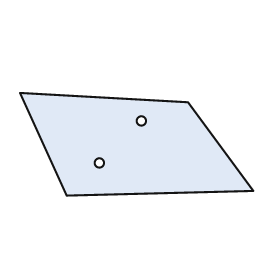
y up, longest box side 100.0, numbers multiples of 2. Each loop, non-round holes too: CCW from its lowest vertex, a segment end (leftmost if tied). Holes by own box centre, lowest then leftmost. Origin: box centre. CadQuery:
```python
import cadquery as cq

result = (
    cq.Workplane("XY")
    .moveTo(-30.0, -22.0)
    .lineTo(50.0, -20.0)
    .lineTo(22.0, 18.0)
    .lineTo(-50.0, 22.0)
    .close()
    .moveTo(-16.0, -8.0)
    .circle(2.0)
    .moveTo(2.0, 10.0)
    .circle(2.0)
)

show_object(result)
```